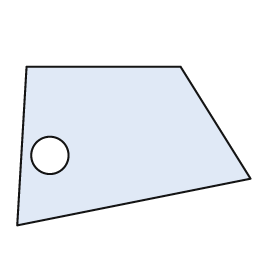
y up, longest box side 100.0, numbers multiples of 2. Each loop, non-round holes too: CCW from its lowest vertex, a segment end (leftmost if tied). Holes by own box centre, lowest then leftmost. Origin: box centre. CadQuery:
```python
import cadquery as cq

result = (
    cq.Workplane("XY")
    .moveTo(-50.0, -34.0)
    .lineTo(50.0, -14.0)
    .lineTo(20.0, 34.0)
    .lineTo(-46.0, 34.0)
    .close()
    .moveTo(-36.0, -4.0)
    .circle(8.0)
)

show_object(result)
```